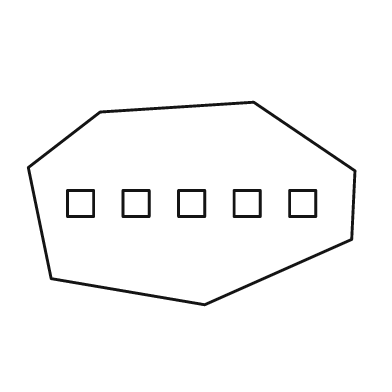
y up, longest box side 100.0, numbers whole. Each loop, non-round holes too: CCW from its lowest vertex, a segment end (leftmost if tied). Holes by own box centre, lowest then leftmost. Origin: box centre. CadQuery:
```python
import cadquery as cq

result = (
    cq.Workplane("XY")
    .moveTo(4.0, -31.0)
    .lineTo(49.0, -11.0)
    .lineTo(50.0, 10.0)
    .lineTo(19.0, 31.0)
    .lineTo(-28.0, 28.0)
    .lineTo(-50.0, 11.0)
    .lineTo(-43.0, -23.0)
    .close()
    .moveTo(-38.0, -4.0)
    .lineTo(-30.0, -4.0)
    .lineTo(-30.0, 4.0)
    .lineTo(-38.0, 4.0)
    .close()
    .moveTo(-21.0, -4.0)
    .lineTo(-13.0, -4.0)
    .lineTo(-13.0, 4.0)
    .lineTo(-21.0, 4.0)
    .close()
    .moveTo(-4.0, -4.0)
    .lineTo(4.0, -4.0)
    .lineTo(4.0, 4.0)
    .lineTo(-4.0, 4.0)
    .close()
    .moveTo(13.0, -4.0)
    .lineTo(21.0, -4.0)
    .lineTo(21.0, 4.0)
    .lineTo(13.0, 4.0)
    .close()
    .moveTo(30.0, -4.0)
    .lineTo(38.0, -4.0)
    .lineTo(38.0, 4.0)
    .lineTo(30.0, 4.0)
    .close()
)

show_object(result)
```